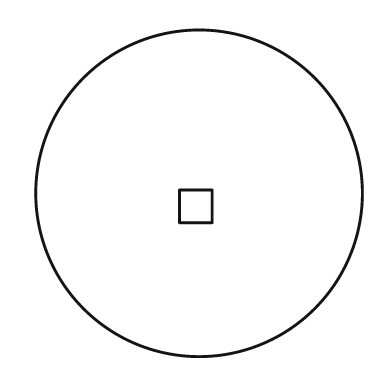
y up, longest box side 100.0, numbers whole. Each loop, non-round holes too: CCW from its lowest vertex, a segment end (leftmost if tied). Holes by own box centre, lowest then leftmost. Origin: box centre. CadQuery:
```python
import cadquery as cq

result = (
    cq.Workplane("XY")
    .moveTo(0.0, 0.0)
    .circle(50.0)
    .moveTo(-6.0, -9.0)
    .lineTo(4.0, -9.0)
    .lineTo(4.0, 1.0)
    .lineTo(-6.0, 1.0)
    .close()
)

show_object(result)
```